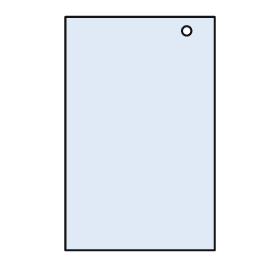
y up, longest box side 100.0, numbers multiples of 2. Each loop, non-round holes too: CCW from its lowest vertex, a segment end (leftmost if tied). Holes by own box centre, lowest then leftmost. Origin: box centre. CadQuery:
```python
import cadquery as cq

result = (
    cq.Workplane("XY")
    .moveTo(-32.0, -50.0)
    .lineTo(32.0, -50.0)
    .lineTo(32.0, 50.0)
    .lineTo(-32.0, 50.0)
    .close()
    .moveTo(20.0, 44.0)
    .circle(2.0)
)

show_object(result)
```